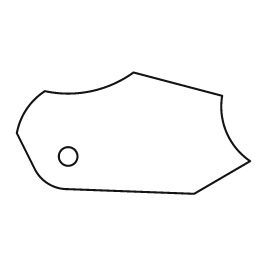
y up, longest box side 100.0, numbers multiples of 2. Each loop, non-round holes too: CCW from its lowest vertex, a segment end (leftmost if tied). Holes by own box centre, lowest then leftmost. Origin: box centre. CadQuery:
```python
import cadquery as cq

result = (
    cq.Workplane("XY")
    .moveTo(26.0, -26.0)
    .lineTo(50.0, -12.0)
    .threePointArc((40.0, 0.0), (38.0, 16.0))
    .lineTo(0.0, 26.0)
    .threePointArc((-18.0, 18.0), (-38.0, 18.0))
    .threePointArc((-46.0, 10.0), (-50.0, 0.0))
    .lineTo(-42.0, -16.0)
    .threePointArc((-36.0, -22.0), (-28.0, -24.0))
    .close()
    .moveTo(-28.0, -10.0)
    .circle(4.0)
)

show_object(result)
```